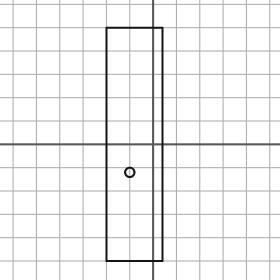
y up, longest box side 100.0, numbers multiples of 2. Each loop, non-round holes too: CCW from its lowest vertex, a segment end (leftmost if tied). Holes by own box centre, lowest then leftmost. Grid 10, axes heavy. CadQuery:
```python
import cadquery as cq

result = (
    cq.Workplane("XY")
    .moveTo(-20.0, -50.0)
    .lineTo(4.0, -50.0)
    .lineTo(4.0, 50.0)
    .lineTo(-20.0, 50.0)
    .close()
    .moveTo(-10.0, -12.0)
    .circle(2.0)
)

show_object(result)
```